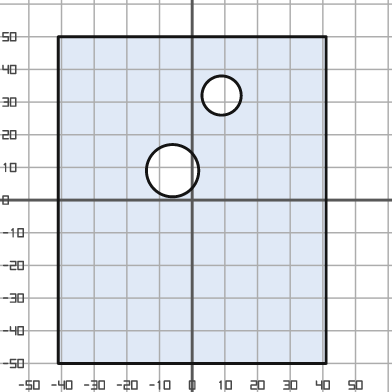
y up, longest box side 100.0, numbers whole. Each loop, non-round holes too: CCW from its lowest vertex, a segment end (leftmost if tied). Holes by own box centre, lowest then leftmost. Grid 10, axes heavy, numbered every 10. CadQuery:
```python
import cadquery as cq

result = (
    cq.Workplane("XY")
    .moveTo(-41.0, -50.0)
    .lineTo(41.0, -50.0)
    .lineTo(41.0, 50.0)
    .lineTo(-41.0, 50.0)
    .close()
    .moveTo(-6.0, 9.0)
    .circle(8.0)
    .moveTo(9.0, 32.0)
    .circle(6.0)
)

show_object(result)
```